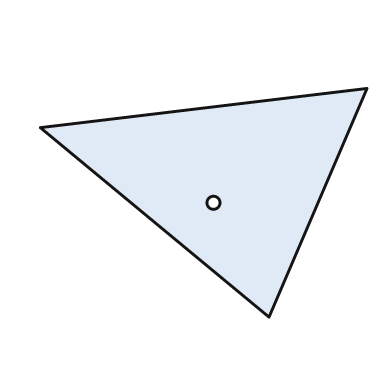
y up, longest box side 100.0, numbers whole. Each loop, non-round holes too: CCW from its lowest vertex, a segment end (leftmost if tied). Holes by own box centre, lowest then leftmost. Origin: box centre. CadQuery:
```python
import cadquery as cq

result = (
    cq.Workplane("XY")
    .moveTo(20.0, -35.0)
    .lineTo(50.0, 35.0)
    .lineTo(-50.0, 23.0)
    .close()
    .moveTo(3.0, 0.0)
    .circle(2.0)
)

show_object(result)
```